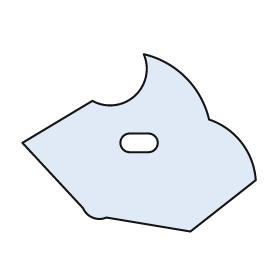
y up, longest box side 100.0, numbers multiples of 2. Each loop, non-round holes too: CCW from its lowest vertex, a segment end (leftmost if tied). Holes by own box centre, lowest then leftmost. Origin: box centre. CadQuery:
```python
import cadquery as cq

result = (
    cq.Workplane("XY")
    .moveTo(22.0, -38.0)
    .lineTo(50.0, -16.0)
    .threePointArc((44.0, 0.0), (30.0, 10.0))
    .threePointArc((20.0, 28.0), (2.0, 38.0))
    .threePointArc((-2.0, 20.0), (-20.0, 18.0))
    .lineTo(-50.0, 0.0)
    .lineTo(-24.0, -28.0)
    .threePointArc((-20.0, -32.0), (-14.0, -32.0))
    .close()
    .moveTo(-4.0, -4.0)
    .lineTo(4.0, -4.0)
    .threePointArc((8.0, 0.0), (4.0, 4.0))
    .lineTo(-4.0, 4.0)
    .threePointArc((-8.0, 0.0), (-4.0, -4.0))
    .close()
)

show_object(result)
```